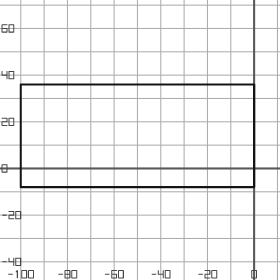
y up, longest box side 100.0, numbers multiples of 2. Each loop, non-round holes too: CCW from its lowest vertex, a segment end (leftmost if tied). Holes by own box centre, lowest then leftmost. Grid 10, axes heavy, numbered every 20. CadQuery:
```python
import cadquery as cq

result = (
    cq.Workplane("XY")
    .moveTo(-100.0, -8.0)
    .lineTo(0.0, -8.0)
    .lineTo(0.0, 36.0)
    .lineTo(-100.0, 36.0)
    .close()
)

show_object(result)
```